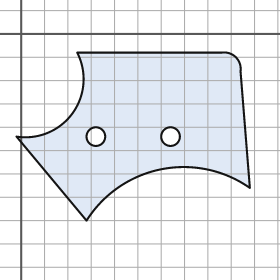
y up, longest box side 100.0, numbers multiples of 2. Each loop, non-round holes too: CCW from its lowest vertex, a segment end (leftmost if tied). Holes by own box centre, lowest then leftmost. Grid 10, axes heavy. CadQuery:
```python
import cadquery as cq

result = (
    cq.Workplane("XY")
    .moveTo(28.0, -80.0)
    .threePointArc((60.0, -58.0), (98.0, -66.0))
    .lineTo(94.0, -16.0)
    .threePointArc((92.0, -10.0), (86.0, -8.0))
    .lineTo(24.0, -8.0)
    .threePointArc((22.0, -34.0), (-2.0, -44.0))
    .close()
    .moveTo(32.0, -44.0)
    .circle(4.0)
    .moveTo(64.0, -44.0)
    .circle(4.0)
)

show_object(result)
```